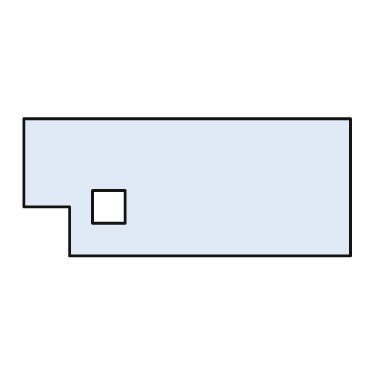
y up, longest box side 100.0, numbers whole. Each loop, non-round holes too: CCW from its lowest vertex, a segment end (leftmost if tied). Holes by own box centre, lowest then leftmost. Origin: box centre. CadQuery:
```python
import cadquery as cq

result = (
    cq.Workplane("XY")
    .moveTo(-36.0, -21.0)
    .lineTo(50.0, -21.0)
    .lineTo(50.0, 21.0)
    .lineTo(-50.0, 21.0)
    .lineTo(-50.0, -6.0)
    .lineTo(-36.0, -6.0)
    .close()
    .moveTo(-29.0, -11.0)
    .lineTo(-19.0, -11.0)
    .lineTo(-19.0, -1.0)
    .lineTo(-29.0, -1.0)
    .close()
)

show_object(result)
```